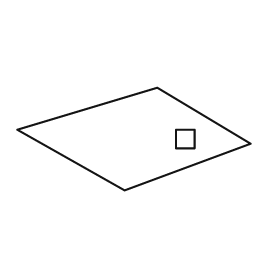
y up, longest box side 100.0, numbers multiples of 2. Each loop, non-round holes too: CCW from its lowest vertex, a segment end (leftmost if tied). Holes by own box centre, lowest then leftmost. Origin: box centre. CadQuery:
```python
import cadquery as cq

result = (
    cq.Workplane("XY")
    .moveTo(-4.0, -22.0)
    .lineTo(50.0, -2.0)
    .lineTo(10.0, 22.0)
    .lineTo(-50.0, 4.0)
    .close()
    .moveTo(18.0, -4.0)
    .lineTo(26.0, -4.0)
    .lineTo(26.0, 4.0)
    .lineTo(18.0, 4.0)
    .close()
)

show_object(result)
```